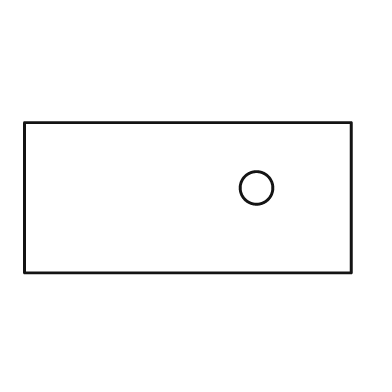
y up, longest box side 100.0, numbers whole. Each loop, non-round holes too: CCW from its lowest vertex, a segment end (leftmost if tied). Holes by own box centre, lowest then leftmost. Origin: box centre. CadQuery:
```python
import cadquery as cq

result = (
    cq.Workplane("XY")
    .moveTo(-50.0, -23.0)
    .lineTo(50.0, -23.0)
    .lineTo(50.0, 23.0)
    .lineTo(-50.0, 23.0)
    .close()
    .moveTo(21.0, 3.0)
    .circle(5.0)
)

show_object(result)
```